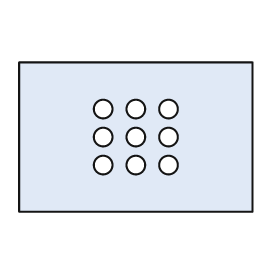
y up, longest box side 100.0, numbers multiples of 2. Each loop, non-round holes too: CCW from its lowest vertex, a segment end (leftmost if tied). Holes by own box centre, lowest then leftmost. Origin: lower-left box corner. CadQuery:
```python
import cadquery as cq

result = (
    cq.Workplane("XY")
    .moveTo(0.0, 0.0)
    .lineTo(100.0, 0.0)
    .lineTo(100.0, 64.0)
    .lineTo(0.0, 64.0)
    .close()
    .moveTo(36.0, 20.0)
    .circle(4.0)
    .moveTo(50.0, 20.0)
    .circle(4.0)
    .moveTo(64.0, 20.0)
    .circle(4.0)
    .moveTo(36.0, 32.0)
    .circle(4.0)
    .moveTo(50.0, 32.0)
    .circle(4.0)
    .moveTo(64.0, 32.0)
    .circle(4.0)
    .moveTo(36.0, 44.0)
    .circle(4.0)
    .moveTo(50.0, 44.0)
    .circle(4.0)
    .moveTo(64.0, 44.0)
    .circle(4.0)
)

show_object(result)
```